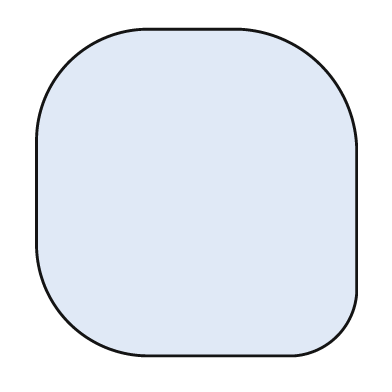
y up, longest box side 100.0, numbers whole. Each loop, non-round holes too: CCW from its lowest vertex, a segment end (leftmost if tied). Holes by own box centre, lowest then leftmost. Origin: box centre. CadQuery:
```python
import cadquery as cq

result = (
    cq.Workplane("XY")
    .moveTo(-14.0, -50.0)
    .lineTo(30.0, -50.0)
    .threePointArc((43.0, -44.0), (49.0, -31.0))
    .lineTo(49.0, 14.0)
    .threePointArc((38.0, 39.0), (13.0, 50.0))
    .lineTo(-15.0, 50.0)
    .threePointArc((-39.0, 40.0), (-49.0, 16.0))
    .lineTo(-49.0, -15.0)
    .threePointArc((-39.0, -40.0), (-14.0, -50.0))
    .close()
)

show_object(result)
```